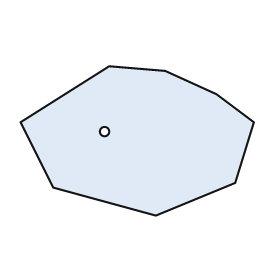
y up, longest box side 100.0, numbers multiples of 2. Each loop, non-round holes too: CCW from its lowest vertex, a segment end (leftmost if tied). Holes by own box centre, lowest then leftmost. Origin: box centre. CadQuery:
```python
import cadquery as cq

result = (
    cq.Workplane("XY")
    .moveTo(8.0, -32.0)
    .lineTo(42.0, -18.0)
    .lineTo(50.0, 8.0)
    .lineTo(34.0, 20.0)
    .lineTo(12.0, 30.0)
    .lineTo(-12.0, 32.0)
    .lineTo(-50.0, 8.0)
    .lineTo(-36.0, -20.0)
    .close()
    .moveTo(-14.0, 4.0)
    .circle(2.0)
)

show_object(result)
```